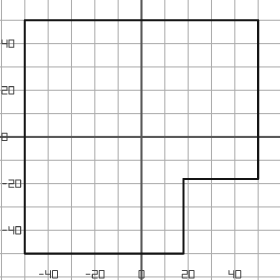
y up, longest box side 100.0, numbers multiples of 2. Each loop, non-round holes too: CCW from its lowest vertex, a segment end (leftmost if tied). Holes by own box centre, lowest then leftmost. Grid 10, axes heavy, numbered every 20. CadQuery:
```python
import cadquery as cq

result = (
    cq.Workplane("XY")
    .moveTo(-50.0, -50.0)
    .lineTo(18.0, -50.0)
    .lineTo(18.0, -18.0)
    .lineTo(50.0, -18.0)
    .lineTo(50.0, 50.0)
    .lineTo(-50.0, 50.0)
    .close()
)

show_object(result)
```